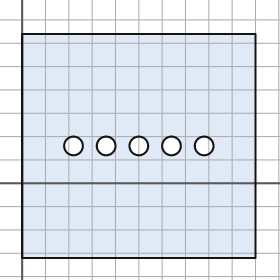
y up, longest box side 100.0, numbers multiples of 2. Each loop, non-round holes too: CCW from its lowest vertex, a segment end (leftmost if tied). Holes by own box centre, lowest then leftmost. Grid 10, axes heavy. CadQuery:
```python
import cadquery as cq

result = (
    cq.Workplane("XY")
    .moveTo(0.0, -32.0)
    .lineTo(100.0, -32.0)
    .lineTo(100.0, 64.0)
    .lineTo(0.0, 64.0)
    .close()
    .moveTo(22.0, 16.0)
    .circle(4.0)
    .moveTo(36.0, 16.0)
    .circle(4.0)
    .moveTo(50.0, 16.0)
    .circle(4.0)
    .moveTo(64.0, 16.0)
    .circle(4.0)
    .moveTo(78.0, 16.0)
    .circle(4.0)
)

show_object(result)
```